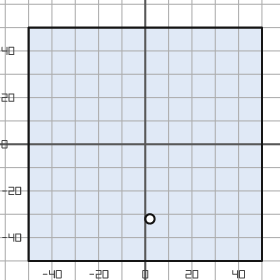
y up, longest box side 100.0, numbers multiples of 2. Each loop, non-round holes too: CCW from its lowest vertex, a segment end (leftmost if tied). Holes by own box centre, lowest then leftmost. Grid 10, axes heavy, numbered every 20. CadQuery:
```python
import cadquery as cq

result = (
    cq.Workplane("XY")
    .moveTo(-50.0, -50.0)
    .lineTo(50.0, -50.0)
    .lineTo(50.0, 50.0)
    .lineTo(-50.0, 50.0)
    .close()
    .moveTo(2.0, -32.0)
    .circle(2.0)
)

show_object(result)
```